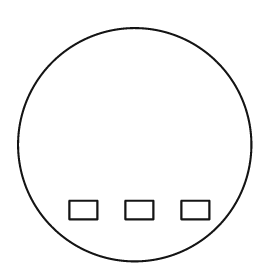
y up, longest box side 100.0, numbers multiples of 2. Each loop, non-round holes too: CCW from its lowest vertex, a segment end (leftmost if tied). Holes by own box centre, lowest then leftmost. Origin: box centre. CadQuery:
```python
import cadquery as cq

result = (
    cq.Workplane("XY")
    .moveTo(0.0, 0.0)
    .circle(50.0)
    .moveTo(-28.0, -32.0)
    .lineTo(-16.0, -32.0)
    .lineTo(-16.0, -24.0)
    .lineTo(-28.0, -24.0)
    .close()
    .moveTo(-4.0, -32.0)
    .lineTo(8.0, -32.0)
    .lineTo(8.0, -24.0)
    .lineTo(-4.0, -24.0)
    .close()
    .moveTo(20.0, -32.0)
    .lineTo(32.0, -32.0)
    .lineTo(32.0, -24.0)
    .lineTo(20.0, -24.0)
    .close()
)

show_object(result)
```